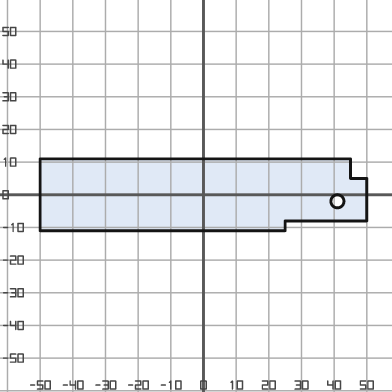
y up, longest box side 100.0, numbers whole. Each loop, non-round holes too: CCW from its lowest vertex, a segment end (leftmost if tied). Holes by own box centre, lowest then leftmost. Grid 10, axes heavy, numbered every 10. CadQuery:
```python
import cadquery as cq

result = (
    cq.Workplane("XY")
    .moveTo(-50.0, -11.0)
    .lineTo(25.0, -11.0)
    .lineTo(25.0, -8.0)
    .lineTo(50.0, -8.0)
    .lineTo(50.0, 5.0)
    .lineTo(45.0, 5.0)
    .lineTo(45.0, 11.0)
    .lineTo(-50.0, 11.0)
    .close()
    .moveTo(41.0, -2.0)
    .circle(2.0)
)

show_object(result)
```